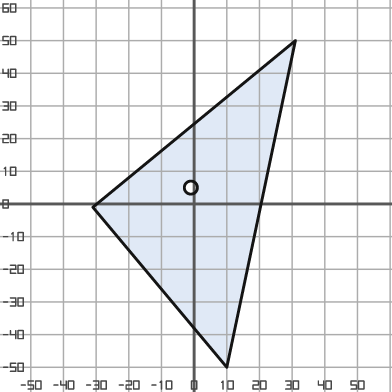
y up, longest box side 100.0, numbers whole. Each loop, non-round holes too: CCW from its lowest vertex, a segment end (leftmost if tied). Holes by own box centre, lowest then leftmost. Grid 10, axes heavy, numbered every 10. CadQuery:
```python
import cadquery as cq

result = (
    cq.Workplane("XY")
    .moveTo(10.0, -50.0)
    .lineTo(31.0, 50.0)
    .lineTo(-31.0, -1.0)
    .close()
    .moveTo(-1.0, 5.0)
    .circle(2.0)
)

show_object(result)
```